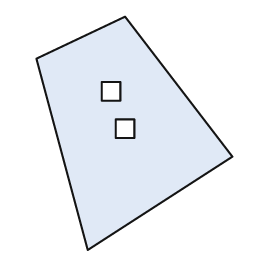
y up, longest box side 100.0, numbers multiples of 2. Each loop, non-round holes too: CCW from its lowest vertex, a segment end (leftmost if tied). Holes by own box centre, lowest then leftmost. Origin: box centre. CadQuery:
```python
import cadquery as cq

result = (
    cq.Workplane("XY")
    .moveTo(-20.0, -50.0)
    .lineTo(42.0, -10.0)
    .lineTo(-4.0, 50.0)
    .lineTo(-42.0, 32.0)
    .close()
    .moveTo(-8.0, -2.0)
    .lineTo(0.0, -2.0)
    .lineTo(0.0, 6.0)
    .lineTo(-8.0, 6.0)
    .close()
    .moveTo(-14.0, 14.0)
    .lineTo(-6.0, 14.0)
    .lineTo(-6.0, 22.0)
    .lineTo(-14.0, 22.0)
    .close()
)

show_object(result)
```